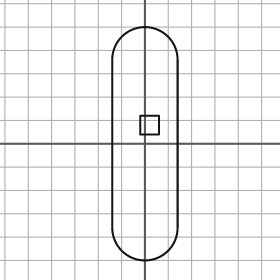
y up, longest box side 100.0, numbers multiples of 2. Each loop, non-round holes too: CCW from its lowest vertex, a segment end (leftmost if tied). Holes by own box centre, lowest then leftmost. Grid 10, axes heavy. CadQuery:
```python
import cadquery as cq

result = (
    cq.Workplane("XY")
    .moveTo(-14.0, -36.0)
    .threePointArc((0.0, -50.0), (14.0, -36.0))
    .lineTo(14.0, 36.0)
    .threePointArc((0.0, 50.0), (-14.0, 36.0))
    .close()
    .moveTo(-2.0, 4.0)
    .lineTo(6.0, 4.0)
    .lineTo(6.0, 12.0)
    .lineTo(-2.0, 12.0)
    .close()
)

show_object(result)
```